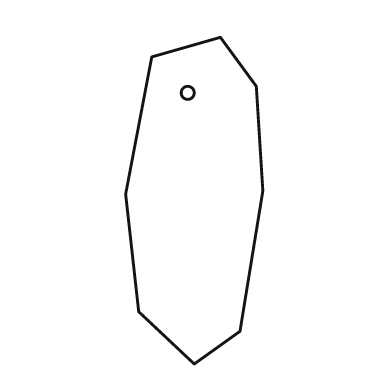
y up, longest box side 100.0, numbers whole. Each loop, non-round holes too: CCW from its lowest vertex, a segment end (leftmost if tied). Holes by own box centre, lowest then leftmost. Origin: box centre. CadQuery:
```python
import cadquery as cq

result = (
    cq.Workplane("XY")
    .moveTo(0.0, -50.0)
    .lineTo(14.0, -40.0)
    .lineTo(21.0, 3.0)
    .lineTo(19.0, 35.0)
    .lineTo(8.0, 50.0)
    .lineTo(-13.0, 44.0)
    .lineTo(-21.0, 2.0)
    .lineTo(-17.0, -34.0)
    .close()
    .moveTo(-2.0, 33.0)
    .circle(2.0)
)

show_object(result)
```